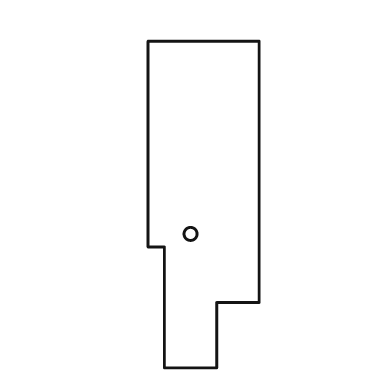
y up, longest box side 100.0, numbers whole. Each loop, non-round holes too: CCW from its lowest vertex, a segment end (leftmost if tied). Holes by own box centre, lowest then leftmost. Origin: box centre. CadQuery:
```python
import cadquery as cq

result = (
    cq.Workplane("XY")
    .moveTo(-12.0, -50.0)
    .lineTo(4.0, -50.0)
    .lineTo(4.0, -30.0)
    .lineTo(17.0, -30.0)
    .lineTo(17.0, 50.0)
    .lineTo(-17.0, 50.0)
    .lineTo(-17.0, -13.0)
    .lineTo(-12.0, -13.0)
    .close()
    .moveTo(-4.0, -9.0)
    .circle(2.0)
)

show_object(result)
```